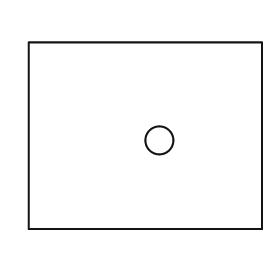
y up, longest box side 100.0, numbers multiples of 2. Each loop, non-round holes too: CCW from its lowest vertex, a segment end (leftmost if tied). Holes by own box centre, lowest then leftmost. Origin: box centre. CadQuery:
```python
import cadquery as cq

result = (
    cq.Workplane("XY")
    .moveTo(-50.0, -40.0)
    .lineTo(50.0, -40.0)
    .lineTo(50.0, 40.0)
    .lineTo(-50.0, 40.0)
    .close()
    .moveTo(6.0, -2.0)
    .circle(6.0)
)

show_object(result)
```